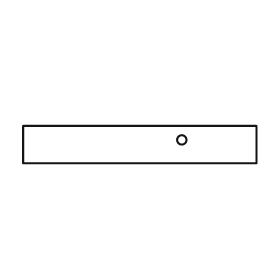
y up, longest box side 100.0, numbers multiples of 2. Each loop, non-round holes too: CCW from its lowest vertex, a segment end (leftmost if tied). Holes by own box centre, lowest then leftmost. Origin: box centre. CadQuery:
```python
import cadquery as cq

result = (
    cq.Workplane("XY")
    .moveTo(-50.0, -8.0)
    .lineTo(50.0, -8.0)
    .lineTo(50.0, 8.0)
    .lineTo(-50.0, 8.0)
    .close()
    .moveTo(18.0, 2.0)
    .circle(2.0)
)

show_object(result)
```